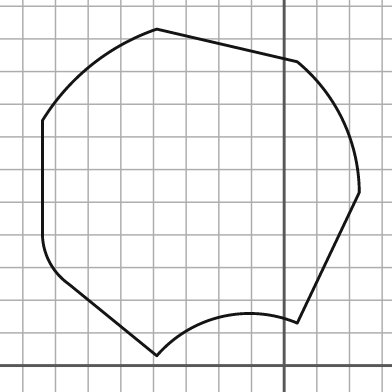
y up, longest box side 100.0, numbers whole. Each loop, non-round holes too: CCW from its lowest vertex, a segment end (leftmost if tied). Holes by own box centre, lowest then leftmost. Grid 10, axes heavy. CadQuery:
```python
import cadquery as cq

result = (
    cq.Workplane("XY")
    .moveTo(-39.0, 3.0)
    .threePointArc((-19.0, 15.0), (4.0, 13.0))
    .lineTo(23.0, 53.0)
    .threePointArc((18.0, 75.0), (4.0, 93.0))
    .lineTo(-39.0, 103.0)
    .threePointArc((-59.0, 92.0), (-74.0, 75.0))
    .lineTo(-74.0, 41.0)
    .threePointArc((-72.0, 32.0), (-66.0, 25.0))
    .close()
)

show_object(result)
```